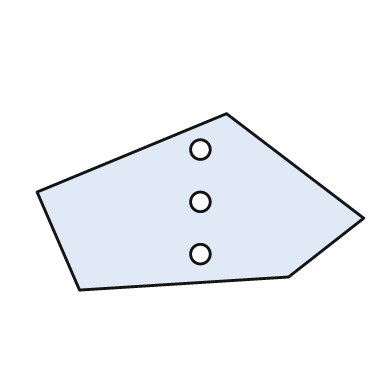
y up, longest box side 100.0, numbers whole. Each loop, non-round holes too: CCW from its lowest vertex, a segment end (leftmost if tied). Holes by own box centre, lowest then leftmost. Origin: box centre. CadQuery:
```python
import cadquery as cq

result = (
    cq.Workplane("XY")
    .moveTo(-37.0, -27.0)
    .lineTo(27.0, -23.0)
    .lineTo(50.0, -5.0)
    .lineTo(8.0, 27.0)
    .lineTo(-50.0, 3.0)
    .close()
    .moveTo(0.0, -16.0)
    .circle(3.0)
    .moveTo(0.0, 0.0)
    .circle(3.0)
    .moveTo(0.0, 16.0)
    .circle(3.0)
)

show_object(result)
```